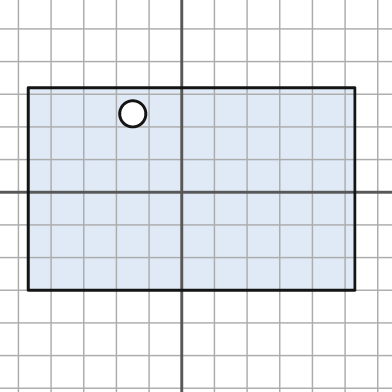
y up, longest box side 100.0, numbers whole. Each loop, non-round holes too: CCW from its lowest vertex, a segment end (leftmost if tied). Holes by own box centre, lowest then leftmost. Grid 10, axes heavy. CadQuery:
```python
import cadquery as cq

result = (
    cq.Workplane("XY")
    .moveTo(-47.0, -30.0)
    .lineTo(53.0, -30.0)
    .lineTo(53.0, 32.0)
    .lineTo(-47.0, 32.0)
    .close()
    .moveTo(-15.0, 24.0)
    .circle(4.0)
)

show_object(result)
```